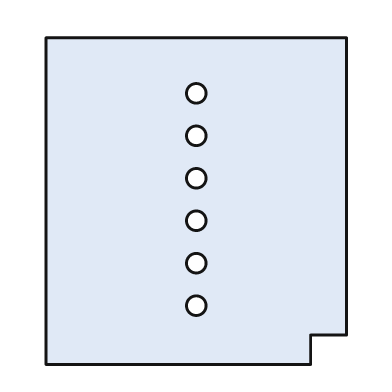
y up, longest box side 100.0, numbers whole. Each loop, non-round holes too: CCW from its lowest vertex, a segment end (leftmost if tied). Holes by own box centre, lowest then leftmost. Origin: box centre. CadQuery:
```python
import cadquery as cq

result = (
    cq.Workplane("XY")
    .moveTo(-46.0, -50.0)
    .lineTo(35.0, -50.0)
    .lineTo(35.0, -41.0)
    .lineTo(46.0, -41.0)
    .lineTo(46.0, 50.0)
    .lineTo(-46.0, 50.0)
    .close()
    .moveTo(0.0, -32.0)
    .circle(3.0)
    .moveTo(0.0, -19.0)
    .circle(3.0)
    .moveTo(0.0, -6.0)
    .circle(3.0)
    .moveTo(0.0, 7.0)
    .circle(3.0)
    .moveTo(0.0, 20.0)
    .circle(3.0)
    .moveTo(0.0, 33.0)
    .circle(3.0)
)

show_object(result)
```